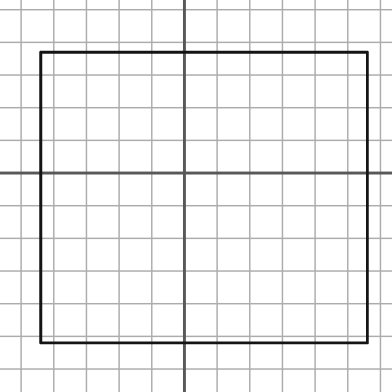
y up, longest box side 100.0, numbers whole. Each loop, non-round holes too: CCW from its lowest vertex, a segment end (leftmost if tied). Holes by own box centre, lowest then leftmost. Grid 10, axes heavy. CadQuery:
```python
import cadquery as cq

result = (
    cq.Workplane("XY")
    .moveTo(-44.0, -52.0)
    .lineTo(56.0, -52.0)
    .lineTo(56.0, 37.0)
    .lineTo(-44.0, 37.0)
    .close()
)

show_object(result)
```